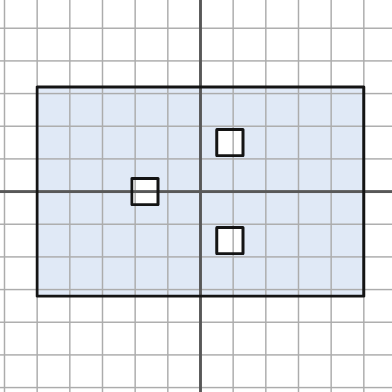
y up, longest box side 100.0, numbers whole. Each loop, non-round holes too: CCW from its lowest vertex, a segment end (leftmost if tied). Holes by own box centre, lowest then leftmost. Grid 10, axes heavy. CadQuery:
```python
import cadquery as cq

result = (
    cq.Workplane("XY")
    .moveTo(-50.0, -32.0)
    .lineTo(50.0, -32.0)
    .lineTo(50.0, 32.0)
    .lineTo(-50.0, 32.0)
    .close()
    .moveTo(5.0, -19.0)
    .lineTo(13.0, -19.0)
    .lineTo(13.0, -11.0)
    .lineTo(5.0, -11.0)
    .close()
    .moveTo(-21.0, -4.0)
    .lineTo(-13.0, -4.0)
    .lineTo(-13.0, 4.0)
    .lineTo(-21.0, 4.0)
    .close()
    .moveTo(5.0, 11.0)
    .lineTo(13.0, 11.0)
    .lineTo(13.0, 19.0)
    .lineTo(5.0, 19.0)
    .close()
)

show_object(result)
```